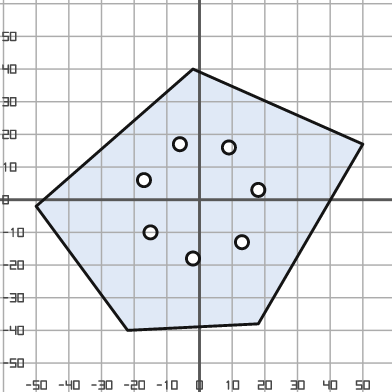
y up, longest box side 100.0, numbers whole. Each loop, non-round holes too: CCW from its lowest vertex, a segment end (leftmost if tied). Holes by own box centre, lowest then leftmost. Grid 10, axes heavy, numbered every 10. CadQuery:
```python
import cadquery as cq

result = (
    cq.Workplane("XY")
    .moveTo(-22.0, -40.0)
    .lineTo(18.0, -38.0)
    .lineTo(50.0, 17.0)
    .lineTo(-2.0, 40.0)
    .lineTo(-50.0, -2.0)
    .close()
    .moveTo(-2.0, -18.0)
    .circle(2.0)
    .moveTo(13.0, -13.0)
    .circle(2.0)
    .moveTo(-15.0, -10.0)
    .circle(2.0)
    .moveTo(18.0, 3.0)
    .circle(2.0)
    .moveTo(-17.0, 6.0)
    .circle(2.0)
    .moveTo(9.0, 16.0)
    .circle(2.0)
    .moveTo(-6.0, 17.0)
    .circle(2.0)
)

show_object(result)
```